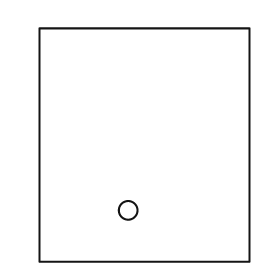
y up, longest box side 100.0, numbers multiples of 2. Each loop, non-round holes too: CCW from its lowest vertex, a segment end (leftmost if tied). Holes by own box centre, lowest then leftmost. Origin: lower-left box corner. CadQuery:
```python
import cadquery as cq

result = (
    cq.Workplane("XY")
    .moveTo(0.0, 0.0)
    .lineTo(90.0, 0.0)
    .lineTo(90.0, 100.0)
    .lineTo(0.0, 100.0)
    .close()
    .moveTo(38.0, 22.0)
    .circle(4.0)
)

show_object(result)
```